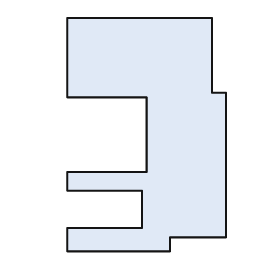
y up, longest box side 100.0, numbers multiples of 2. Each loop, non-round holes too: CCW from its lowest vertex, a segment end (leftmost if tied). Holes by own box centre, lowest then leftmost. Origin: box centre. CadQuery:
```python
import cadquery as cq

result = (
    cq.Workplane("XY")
    .moveTo(-34.0, -50.0)
    .lineTo(10.0, -50.0)
    .lineTo(10.0, -44.0)
    .lineTo(34.0, -44.0)
    .lineTo(34.0, 18.0)
    .lineTo(28.0, 18.0)
    .lineTo(28.0, 50.0)
    .lineTo(-34.0, 50.0)
    .lineTo(-34.0, 16.0)
    .lineTo(0.0, 16.0)
    .lineTo(0.0, -16.0)
    .lineTo(-34.0, -16.0)
    .lineTo(-34.0, -24.0)
    .lineTo(-2.0, -24.0)
    .lineTo(-2.0, -40.0)
    .lineTo(-34.0, -40.0)
    .close()
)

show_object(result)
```